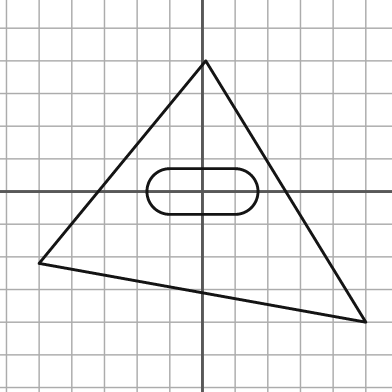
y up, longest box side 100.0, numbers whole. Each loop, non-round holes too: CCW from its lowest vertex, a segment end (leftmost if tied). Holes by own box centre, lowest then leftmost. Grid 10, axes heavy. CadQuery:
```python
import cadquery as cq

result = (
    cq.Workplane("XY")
    .moveTo(50.0, -40.0)
    .lineTo(1.0, 40.0)
    .lineTo(-50.0, -22.0)
    .close()
    .moveTo(-10.0, -7.0)
    .lineTo(10.0, -7.0)
    .threePointArc((17.0, 0.0), (10.0, 7.0))
    .lineTo(-10.0, 7.0)
    .threePointArc((-17.0, 0.0), (-10.0, -7.0))
    .close()
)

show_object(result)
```